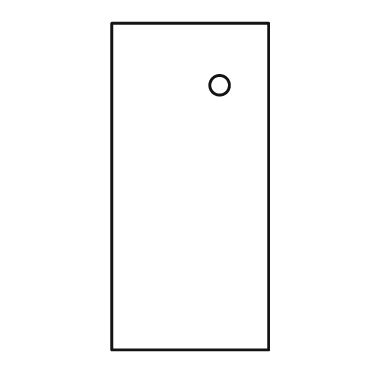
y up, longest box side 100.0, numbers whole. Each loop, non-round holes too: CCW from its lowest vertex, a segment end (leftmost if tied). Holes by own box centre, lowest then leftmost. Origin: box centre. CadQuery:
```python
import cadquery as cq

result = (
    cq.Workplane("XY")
    .moveTo(-24.0, -50.0)
    .lineTo(24.0, -50.0)
    .lineTo(24.0, 50.0)
    .lineTo(-24.0, 50.0)
    .close()
    .moveTo(9.0, 31.0)
    .circle(3.0)
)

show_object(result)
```